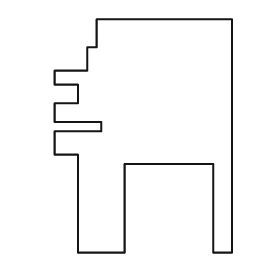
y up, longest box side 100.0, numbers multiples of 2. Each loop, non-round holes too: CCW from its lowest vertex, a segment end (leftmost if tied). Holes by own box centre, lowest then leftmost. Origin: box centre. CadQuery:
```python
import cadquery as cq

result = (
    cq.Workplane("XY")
    .moveTo(-28.0, -50.0)
    .lineTo(-8.0, -50.0)
    .lineTo(-8.0, -12.0)
    .lineTo(30.0, -12.0)
    .lineTo(30.0, -50.0)
    .lineTo(38.0, -50.0)
    .lineTo(38.0, 50.0)
    .lineTo(-20.0, 50.0)
    .lineTo(-20.0, 38.0)
    .lineTo(-24.0, 38.0)
    .lineTo(-24.0, 28.0)
    .lineTo(-38.0, 28.0)
    .lineTo(-38.0, 22.0)
    .lineTo(-28.0, 22.0)
    .lineTo(-28.0, 14.0)
    .lineTo(-38.0, 14.0)
    .lineTo(-38.0, 6.0)
    .lineTo(-18.0, 6.0)
    .lineTo(-18.0, 2.0)
    .lineTo(-38.0, 2.0)
    .lineTo(-38.0, -8.0)
    .lineTo(-28.0, -8.0)
    .close()
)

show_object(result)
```